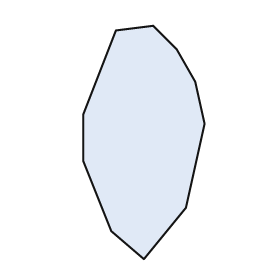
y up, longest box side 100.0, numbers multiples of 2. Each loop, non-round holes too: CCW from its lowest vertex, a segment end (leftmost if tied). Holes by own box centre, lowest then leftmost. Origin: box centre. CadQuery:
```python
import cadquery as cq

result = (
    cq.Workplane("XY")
    .moveTo(0.0, -50.0)
    .lineTo(18.0, -28.0)
    .lineTo(26.0, 8.0)
    .lineTo(22.0, 26.0)
    .lineTo(14.0, 40.0)
    .lineTo(4.0, 50.0)
    .lineTo(-12.0, 48.0)
    .lineTo(-26.0, 12.0)
    .lineTo(-26.0, -8.0)
    .lineTo(-14.0, -38.0)
    .close()
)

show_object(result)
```